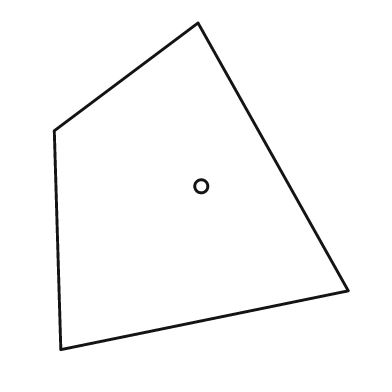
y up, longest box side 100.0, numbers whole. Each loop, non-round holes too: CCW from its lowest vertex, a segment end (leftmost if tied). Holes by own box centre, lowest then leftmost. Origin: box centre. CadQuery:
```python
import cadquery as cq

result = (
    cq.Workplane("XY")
    .moveTo(-43.0, -50.0)
    .lineTo(45.0, -32.0)
    .lineTo(-1.0, 50.0)
    .lineTo(-45.0, 17.0)
    .close()
    .moveTo(0.0, 0.0)
    .circle(2.0)
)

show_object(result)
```